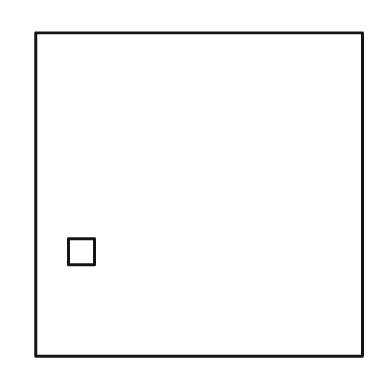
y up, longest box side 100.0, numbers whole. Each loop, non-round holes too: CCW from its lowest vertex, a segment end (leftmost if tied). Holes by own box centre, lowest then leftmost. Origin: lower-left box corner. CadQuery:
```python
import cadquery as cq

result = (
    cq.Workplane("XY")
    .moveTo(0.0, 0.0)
    .lineTo(100.0, 0.0)
    .lineTo(100.0, 99.0)
    .lineTo(0.0, 99.0)
    .close()
    .moveTo(10.0, 28.0)
    .lineTo(18.0, 28.0)
    .lineTo(18.0, 36.0)
    .lineTo(10.0, 36.0)
    .close()
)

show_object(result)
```